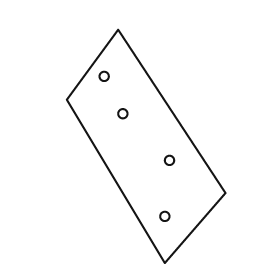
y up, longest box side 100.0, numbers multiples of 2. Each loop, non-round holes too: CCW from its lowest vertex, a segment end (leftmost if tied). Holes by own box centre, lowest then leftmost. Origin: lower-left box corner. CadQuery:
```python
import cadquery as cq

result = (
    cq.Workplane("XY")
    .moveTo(42.0, 0.0)
    .lineTo(68.0, 30.0)
    .lineTo(22.0, 100.0)
    .lineTo(0.0, 70.0)
    .close()
    .moveTo(42.0, 20.0)
    .circle(2.0)
    .moveTo(44.0, 44.0)
    .circle(2.0)
    .moveTo(24.0, 64.0)
    .circle(2.0)
    .moveTo(16.0, 80.0)
    .circle(2.0)
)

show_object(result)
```